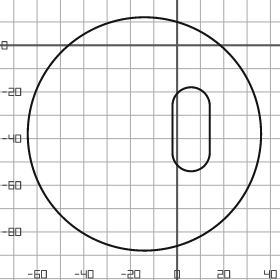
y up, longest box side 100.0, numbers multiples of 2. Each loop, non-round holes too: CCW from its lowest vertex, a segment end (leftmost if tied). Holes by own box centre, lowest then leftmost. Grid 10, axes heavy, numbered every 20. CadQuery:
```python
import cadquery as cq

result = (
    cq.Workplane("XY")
    .moveTo(-14.0, -38.0)
    .circle(50.0)
    .moveTo(-2.0, -46.0)
    .threePointArc((6.0, -54.0), (14.0, -46.0))
    .lineTo(14.0, -26.0)
    .threePointArc((6.0, -18.0), (-2.0, -26.0))
    .close()
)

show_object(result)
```